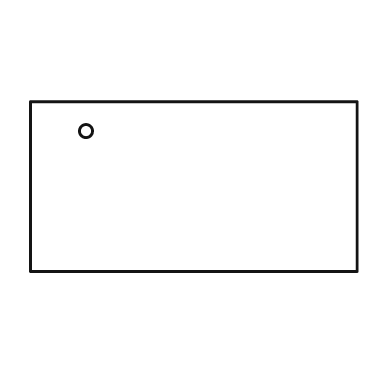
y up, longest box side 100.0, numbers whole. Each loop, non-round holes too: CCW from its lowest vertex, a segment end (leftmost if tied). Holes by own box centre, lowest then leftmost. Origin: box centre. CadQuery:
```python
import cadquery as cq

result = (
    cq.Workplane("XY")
    .moveTo(-50.0, -26.0)
    .lineTo(50.0, -26.0)
    .lineTo(50.0, 26.0)
    .lineTo(-50.0, 26.0)
    .close()
    .moveTo(-33.0, 17.0)
    .circle(2.0)
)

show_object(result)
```